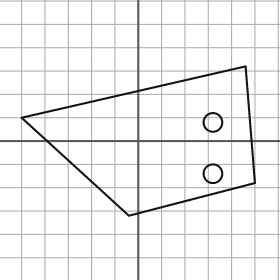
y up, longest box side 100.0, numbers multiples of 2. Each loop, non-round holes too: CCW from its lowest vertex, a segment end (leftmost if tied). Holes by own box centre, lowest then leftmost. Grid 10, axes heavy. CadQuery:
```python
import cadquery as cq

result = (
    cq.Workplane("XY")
    .moveTo(-4.0, -32.0)
    .lineTo(50.0, -18.0)
    .lineTo(46.0, 32.0)
    .lineTo(-50.0, 10.0)
    .close()
    .moveTo(32.0, -14.0)
    .circle(4.0)
    .moveTo(32.0, 8.0)
    .circle(4.0)
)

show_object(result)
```